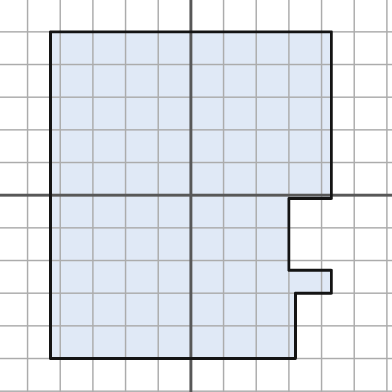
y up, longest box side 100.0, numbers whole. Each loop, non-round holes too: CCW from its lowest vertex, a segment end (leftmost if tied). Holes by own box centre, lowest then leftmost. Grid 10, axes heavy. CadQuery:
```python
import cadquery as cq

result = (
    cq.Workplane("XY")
    .moveTo(-43.0, -50.0)
    .lineTo(32.0, -50.0)
    .lineTo(32.0, -30.0)
    .lineTo(43.0, -30.0)
    .lineTo(43.0, -23.0)
    .lineTo(30.0, -23.0)
    .lineTo(30.0, -1.0)
    .lineTo(43.0, -1.0)
    .lineTo(43.0, 50.0)
    .lineTo(-43.0, 50.0)
    .close()
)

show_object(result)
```